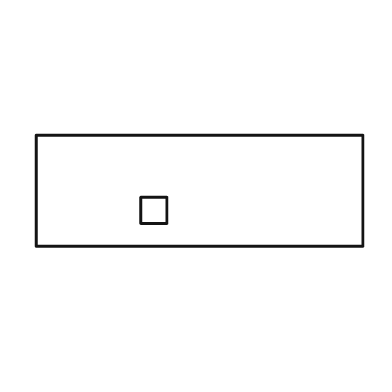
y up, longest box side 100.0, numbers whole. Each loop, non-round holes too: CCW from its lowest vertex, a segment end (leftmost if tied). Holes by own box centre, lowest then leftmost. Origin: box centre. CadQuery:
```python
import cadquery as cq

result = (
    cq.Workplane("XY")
    .moveTo(-50.0, -17.0)
    .lineTo(50.0, -17.0)
    .lineTo(50.0, 17.0)
    .lineTo(-50.0, 17.0)
    .close()
    .moveTo(-18.0, -10.0)
    .lineTo(-10.0, -10.0)
    .lineTo(-10.0, -2.0)
    .lineTo(-18.0, -2.0)
    .close()
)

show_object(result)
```